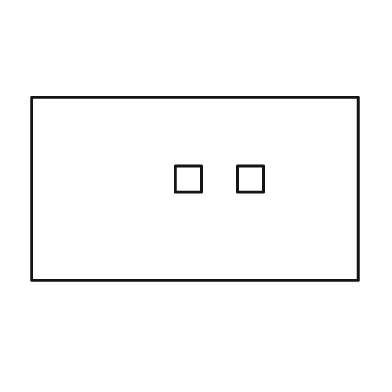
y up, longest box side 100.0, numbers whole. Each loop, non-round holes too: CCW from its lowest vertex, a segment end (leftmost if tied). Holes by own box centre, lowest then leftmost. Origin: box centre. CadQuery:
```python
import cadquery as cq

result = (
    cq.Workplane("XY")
    .moveTo(-50.0, -28.0)
    .lineTo(50.0, -28.0)
    .lineTo(50.0, 28.0)
    .lineTo(-50.0, 28.0)
    .close()
    .moveTo(-6.0, -1.0)
    .lineTo(2.0, -1.0)
    .lineTo(2.0, 7.0)
    .lineTo(-6.0, 7.0)
    .close()
    .moveTo(13.0, -1.0)
    .lineTo(21.0, -1.0)
    .lineTo(21.0, 7.0)
    .lineTo(13.0, 7.0)
    .close()
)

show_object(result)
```